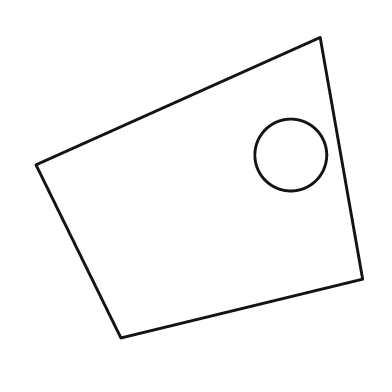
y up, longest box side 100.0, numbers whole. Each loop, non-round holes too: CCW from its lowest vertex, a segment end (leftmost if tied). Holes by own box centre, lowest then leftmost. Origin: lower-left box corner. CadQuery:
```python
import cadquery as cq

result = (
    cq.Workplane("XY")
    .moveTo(26.0, 0.0)
    .lineTo(100.0, 18.0)
    .lineTo(87.0, 92.0)
    .lineTo(0.0, 53.0)
    .close()
    .moveTo(78.0, 56.0)
    .circle(11.0)
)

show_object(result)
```